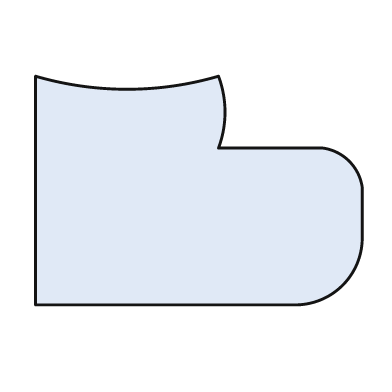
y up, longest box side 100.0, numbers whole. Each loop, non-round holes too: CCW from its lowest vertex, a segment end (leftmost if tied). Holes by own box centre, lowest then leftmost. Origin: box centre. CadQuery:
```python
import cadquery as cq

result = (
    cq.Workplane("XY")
    .moveTo(-50.0, -35.0)
    .lineTo(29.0, -35.0)
    .threePointArc((44.0, -29.0), (50.0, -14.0))
    .lineTo(50.0, 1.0)
    .threePointArc((46.0, 9.0), (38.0, 13.0))
    .lineTo(6.0, 13.0)
    .threePointArc((8.0, 24.0), (6.0, 35.0))
    .threePointArc((-22.0, 31.0), (-50.0, 35.0))
    .close()
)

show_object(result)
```